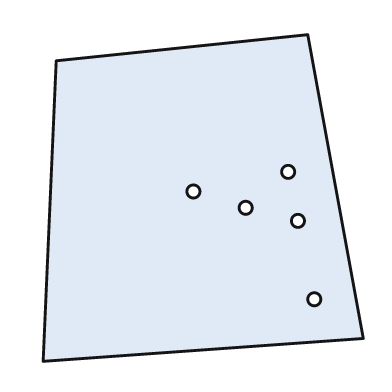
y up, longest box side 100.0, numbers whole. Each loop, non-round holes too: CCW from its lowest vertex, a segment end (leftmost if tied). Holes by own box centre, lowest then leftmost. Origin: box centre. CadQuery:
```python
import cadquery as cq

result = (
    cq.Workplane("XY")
    .moveTo(-49.0, -50.0)
    .lineTo(49.0, -43.0)
    .lineTo(32.0, 50.0)
    .lineTo(-45.0, 42.0)
    .close()
    .moveTo(34.0, -31.0)
    .circle(2.0)
    .moveTo(29.0, -7.0)
    .circle(2.0)
    .moveTo(13.0, -3.0)
    .circle(2.0)
    .moveTo(-3.0, 2.0)
    .circle(2.0)
    .moveTo(26.0, 8.0)
    .circle(2.0)
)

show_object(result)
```